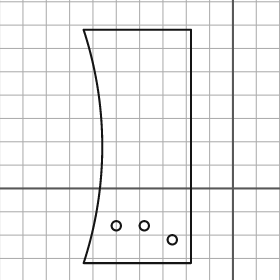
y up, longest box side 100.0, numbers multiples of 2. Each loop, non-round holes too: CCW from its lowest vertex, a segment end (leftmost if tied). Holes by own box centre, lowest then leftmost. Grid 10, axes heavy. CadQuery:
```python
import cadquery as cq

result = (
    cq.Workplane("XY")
    .moveTo(-64.0, -32.0)
    .lineTo(-18.0, -32.0)
    .lineTo(-18.0, 68.0)
    .lineTo(-64.0, 68.0)
    .threePointArc((-56.0, 18.0), (-64.0, -32.0))
    .close()
    .moveTo(-26.0, -22.0)
    .circle(2.0)
    .moveTo(-50.0, -16.0)
    .circle(2.0)
    .moveTo(-38.0, -16.0)
    .circle(2.0)
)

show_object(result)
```